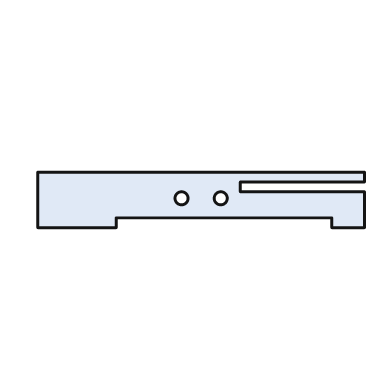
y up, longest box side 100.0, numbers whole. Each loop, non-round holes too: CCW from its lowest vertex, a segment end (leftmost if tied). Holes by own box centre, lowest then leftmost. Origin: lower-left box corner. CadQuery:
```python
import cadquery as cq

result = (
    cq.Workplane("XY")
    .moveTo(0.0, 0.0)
    .lineTo(24.0, 0.0)
    .lineTo(24.0, 3.0)
    .lineTo(90.0, 3.0)
    .lineTo(90.0, 0.0)
    .lineTo(100.0, 0.0)
    .lineTo(100.0, 11.0)
    .lineTo(62.0, 11.0)
    .lineTo(62.0, 14.0)
    .lineTo(100.0, 14.0)
    .lineTo(100.0, 17.0)
    .lineTo(0.0, 17.0)
    .close()
    .moveTo(44.0, 9.0)
    .circle(2.0)
    .moveTo(56.0, 9.0)
    .circle(2.0)
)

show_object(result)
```